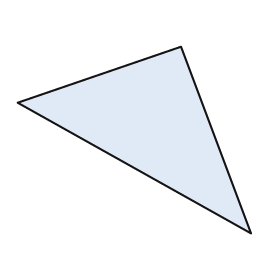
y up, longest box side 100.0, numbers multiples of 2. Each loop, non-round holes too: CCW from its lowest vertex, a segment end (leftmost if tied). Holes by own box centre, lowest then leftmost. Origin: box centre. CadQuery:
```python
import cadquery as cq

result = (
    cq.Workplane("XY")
    .moveTo(50.0, -40.0)
    .lineTo(20.0, 40.0)
    .lineTo(-50.0, 16.0)
    .close()
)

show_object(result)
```